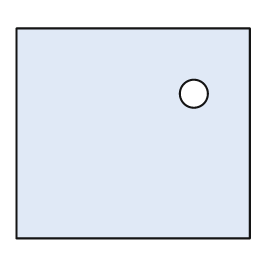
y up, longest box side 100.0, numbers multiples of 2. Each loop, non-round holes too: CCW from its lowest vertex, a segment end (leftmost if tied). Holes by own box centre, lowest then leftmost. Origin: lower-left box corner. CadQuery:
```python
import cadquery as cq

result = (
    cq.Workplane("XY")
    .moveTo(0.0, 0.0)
    .lineTo(100.0, 0.0)
    .lineTo(100.0, 90.0)
    .lineTo(0.0, 90.0)
    .close()
    .moveTo(76.0, 62.0)
    .circle(6.0)
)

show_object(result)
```